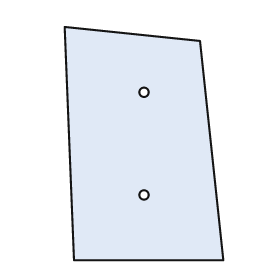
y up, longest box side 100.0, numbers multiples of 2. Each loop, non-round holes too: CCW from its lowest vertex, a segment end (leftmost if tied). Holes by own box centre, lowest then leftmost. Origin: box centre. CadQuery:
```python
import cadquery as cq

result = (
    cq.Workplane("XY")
    .moveTo(-30.0, -50.0)
    .lineTo(34.0, -50.0)
    .lineTo(24.0, 44.0)
    .lineTo(-34.0, 50.0)
    .close()
    .moveTo(0.0, -22.0)
    .circle(2.0)
    .moveTo(0.0, 22.0)
    .circle(2.0)
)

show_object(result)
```